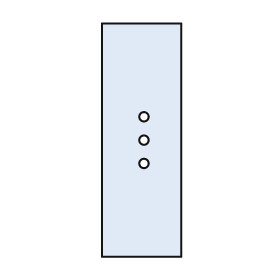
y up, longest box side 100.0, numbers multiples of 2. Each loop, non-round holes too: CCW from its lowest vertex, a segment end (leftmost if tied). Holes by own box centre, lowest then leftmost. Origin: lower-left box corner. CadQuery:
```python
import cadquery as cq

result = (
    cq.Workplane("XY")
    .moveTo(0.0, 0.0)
    .lineTo(34.0, 0.0)
    .lineTo(34.0, 100.0)
    .lineTo(0.0, 100.0)
    .close()
    .moveTo(18.0, 40.0)
    .circle(2.0)
    .moveTo(18.0, 50.0)
    .circle(2.0)
    .moveTo(18.0, 60.0)
    .circle(2.0)
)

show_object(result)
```